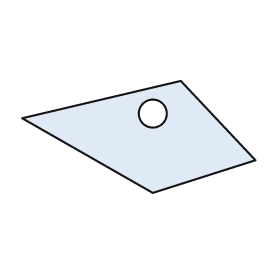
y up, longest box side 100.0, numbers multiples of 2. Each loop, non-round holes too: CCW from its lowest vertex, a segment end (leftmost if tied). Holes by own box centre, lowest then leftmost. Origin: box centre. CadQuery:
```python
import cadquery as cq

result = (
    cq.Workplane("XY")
    .moveTo(6.0, -24.0)
    .lineTo(50.0, -10.0)
    .lineTo(18.0, 24.0)
    .lineTo(-50.0, 8.0)
    .close()
    .moveTo(6.0, 10.0)
    .circle(6.0)
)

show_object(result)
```